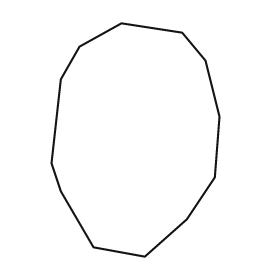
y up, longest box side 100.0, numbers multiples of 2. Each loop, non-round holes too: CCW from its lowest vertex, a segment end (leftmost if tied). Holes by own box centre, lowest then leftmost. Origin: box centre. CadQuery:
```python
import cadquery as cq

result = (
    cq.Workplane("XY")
    .moveTo(4.0, -50.0)
    .lineTo(22.0, -34.0)
    .lineTo(34.0, -16.0)
    .lineTo(36.0, 10.0)
    .lineTo(30.0, 34.0)
    .lineTo(20.0, 46.0)
    .lineTo(-6.0, 50.0)
    .lineTo(-24.0, 40.0)
    .lineTo(-32.0, 26.0)
    .lineTo(-36.0, -10.0)
    .lineTo(-32.0, -22.0)
    .lineTo(-18.0, -46.0)
    .close()
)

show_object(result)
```